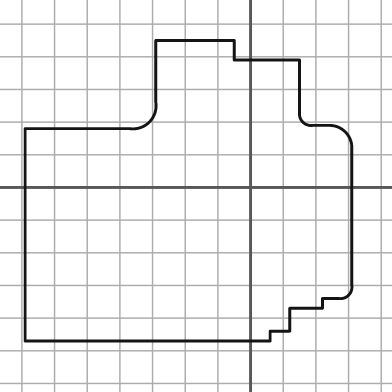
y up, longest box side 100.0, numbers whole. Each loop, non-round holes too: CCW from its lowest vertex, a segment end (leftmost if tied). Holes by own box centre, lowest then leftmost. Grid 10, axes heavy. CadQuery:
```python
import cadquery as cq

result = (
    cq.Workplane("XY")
    .moveTo(-69.0, -47.0)
    .lineTo(6.0, -47.0)
    .lineTo(6.0, -44.0)
    .lineTo(12.0, -44.0)
    .lineTo(12.0, -37.0)
    .lineTo(22.0, -37.0)
    .lineTo(22.0, -34.0)
    .lineTo(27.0, -34.0)
    .threePointArc((30.0, -33.0), (31.0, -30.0))
    .lineTo(31.0, 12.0)
    .threePointArc((29.0, 17.0), (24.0, 19.0))
    .lineTo(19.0, 19.0)
    .threePointArc((16.0, 20.0), (15.0, 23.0))
    .lineTo(15.0, 39.0)
    .lineTo(-5.0, 39.0)
    .lineTo(-5.0, 45.0)
    .lineTo(-29.0, 45.0)
    .lineTo(-29.0, 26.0)
    .threePointArc((-31.0, 20.0), (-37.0, 18.0))
    .lineTo(-69.0, 18.0)
    .close()
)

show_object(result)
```